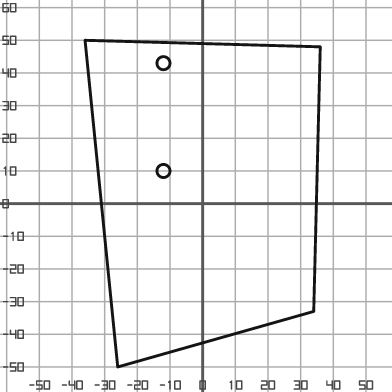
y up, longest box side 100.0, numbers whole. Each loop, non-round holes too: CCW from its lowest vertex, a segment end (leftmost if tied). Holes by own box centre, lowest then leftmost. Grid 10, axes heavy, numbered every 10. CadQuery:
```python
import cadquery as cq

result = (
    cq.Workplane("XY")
    .moveTo(-26.0, -50.0)
    .lineTo(34.0, -33.0)
    .lineTo(36.0, 48.0)
    .lineTo(-36.0, 50.0)
    .close()
    .moveTo(-12.0, 10.0)
    .circle(2.0)
    .moveTo(-12.0, 43.0)
    .circle(2.0)
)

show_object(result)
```